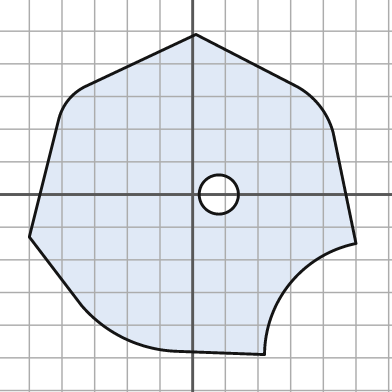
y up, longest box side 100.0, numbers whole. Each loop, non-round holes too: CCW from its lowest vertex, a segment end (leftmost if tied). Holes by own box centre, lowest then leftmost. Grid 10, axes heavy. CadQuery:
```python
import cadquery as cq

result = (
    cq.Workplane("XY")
    .moveTo(22.0, -49.0)
    .threePointArc((30.0, -27.0), (50.0, -15.0))
    .lineTo(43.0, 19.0)
    .threePointArc((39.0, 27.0), (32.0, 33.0))
    .lineTo(1.0, 49.0)
    .lineTo(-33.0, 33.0)
    .threePointArc((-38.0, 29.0), (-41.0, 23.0))
    .lineTo(-50.0, -13.0)
    .lineTo(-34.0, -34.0)
    .threePointArc((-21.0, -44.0), (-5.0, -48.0))
    .close()
    .moveTo(8.0, 0.0)
    .circle(6.0)
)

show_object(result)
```